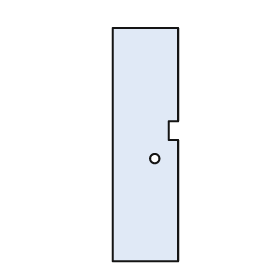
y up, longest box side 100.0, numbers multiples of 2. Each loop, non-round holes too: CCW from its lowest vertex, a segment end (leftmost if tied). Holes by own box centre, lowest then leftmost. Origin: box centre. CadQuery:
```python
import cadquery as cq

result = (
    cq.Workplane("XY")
    .moveTo(-14.0, -50.0)
    .lineTo(14.0, -50.0)
    .lineTo(14.0, 2.0)
    .lineTo(10.0, 2.0)
    .lineTo(10.0, 10.0)
    .lineTo(14.0, 10.0)
    .lineTo(14.0, 50.0)
    .lineTo(-14.0, 50.0)
    .close()
    .moveTo(4.0, -6.0)
    .circle(2.0)
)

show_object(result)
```